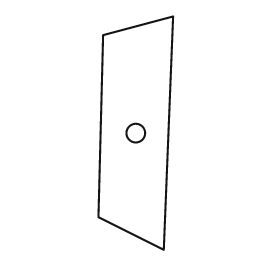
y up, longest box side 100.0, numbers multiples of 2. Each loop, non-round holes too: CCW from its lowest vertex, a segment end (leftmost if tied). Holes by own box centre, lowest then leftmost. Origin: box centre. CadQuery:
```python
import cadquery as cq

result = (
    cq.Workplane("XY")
    .moveTo(12.0, -50.0)
    .lineTo(16.0, 50.0)
    .lineTo(-14.0, 42.0)
    .lineTo(-16.0, -36.0)
    .close()
    .moveTo(0.0, 0.0)
    .circle(4.0)
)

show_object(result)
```